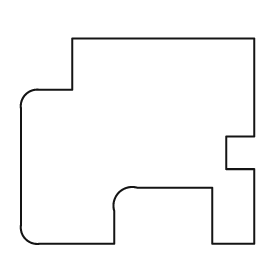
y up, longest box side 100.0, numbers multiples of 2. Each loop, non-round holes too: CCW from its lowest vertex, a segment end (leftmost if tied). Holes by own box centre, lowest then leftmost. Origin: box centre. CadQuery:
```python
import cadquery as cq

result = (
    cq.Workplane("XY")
    .moveTo(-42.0, -44.0)
    .lineTo(-10.0, -44.0)
    .lineTo(-10.0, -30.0)
    .threePointArc((-8.0, -22.0), (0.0, -20.0))
    .lineTo(32.0, -20.0)
    .lineTo(32.0, -44.0)
    .lineTo(50.0, -44.0)
    .lineTo(50.0, -12.0)
    .lineTo(38.0, -12.0)
    .lineTo(38.0, 2.0)
    .lineTo(50.0, 2.0)
    .lineTo(50.0, 44.0)
    .lineTo(-28.0, 44.0)
    .lineTo(-28.0, 22.0)
    .lineTo(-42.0, 22.0)
    .threePointArc((-48.0, 20.0), (-50.0, 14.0))
    .lineTo(-50.0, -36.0)
    .threePointArc((-48.0, -42.0), (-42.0, -44.0))
    .close()
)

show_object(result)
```